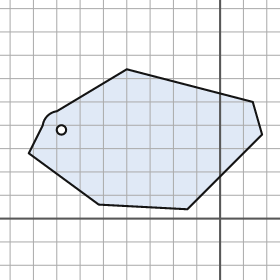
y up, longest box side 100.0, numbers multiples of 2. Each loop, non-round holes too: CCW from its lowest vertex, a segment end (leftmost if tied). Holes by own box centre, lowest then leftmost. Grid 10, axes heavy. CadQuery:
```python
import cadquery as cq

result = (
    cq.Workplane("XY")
    .moveTo(-14.0, 4.0)
    .lineTo(18.0, 36.0)
    .lineTo(14.0, 50.0)
    .lineTo(-40.0, 64.0)
    .lineTo(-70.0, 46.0)
    .threePointArc((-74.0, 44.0), (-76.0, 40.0))
    .lineTo(-82.0, 28.0)
    .lineTo(-52.0, 6.0)
    .close()
    .moveTo(-68.0, 38.0)
    .circle(2.0)
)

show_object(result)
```